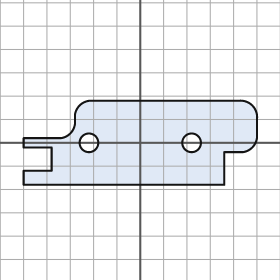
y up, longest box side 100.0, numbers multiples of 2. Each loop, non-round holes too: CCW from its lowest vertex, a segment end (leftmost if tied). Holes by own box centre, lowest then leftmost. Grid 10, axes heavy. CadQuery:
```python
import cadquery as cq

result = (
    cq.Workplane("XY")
    .moveTo(-50.0, -18.0)
    .lineTo(36.0, -18.0)
    .lineTo(36.0, -4.0)
    .lineTo(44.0, -4.0)
    .threePointArc((48.0, -2.0), (50.0, 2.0))
    .lineTo(50.0, 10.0)
    .threePointArc((48.0, 16.0), (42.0, 18.0))
    .lineTo(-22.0, 18.0)
    .threePointArc((-26.0, 16.0), (-28.0, 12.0))
    .lineTo(-28.0, 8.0)
    .threePointArc((-30.0, 4.0), (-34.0, 2.0))
    .lineTo(-50.0, 2.0)
    .lineTo(-50.0, -2.0)
    .lineTo(-38.0, -2.0)
    .lineTo(-38.0, -12.0)
    .lineTo(-50.0, -12.0)
    .close()
    .moveTo(-22.0, 0.0)
    .circle(4.0)
    .moveTo(22.0, 0.0)
    .circle(4.0)
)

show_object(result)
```